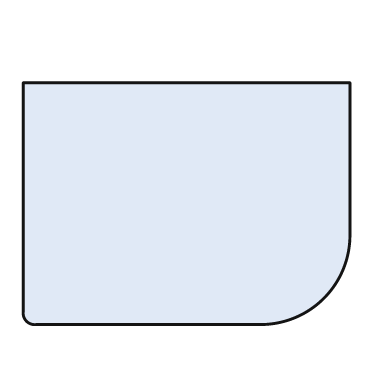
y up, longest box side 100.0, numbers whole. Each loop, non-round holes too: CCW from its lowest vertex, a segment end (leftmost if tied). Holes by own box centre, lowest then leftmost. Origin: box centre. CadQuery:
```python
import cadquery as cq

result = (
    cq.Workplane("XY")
    .moveTo(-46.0, -37.0)
    .lineTo(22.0, -37.0)
    .threePointArc((42.0, -29.0), (50.0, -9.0))
    .lineTo(50.0, 37.0)
    .lineTo(-50.0, 37.0)
    .lineTo(-50.0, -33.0)
    .threePointArc((-49.0, -36.0), (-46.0, -37.0))
    .close()
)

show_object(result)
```